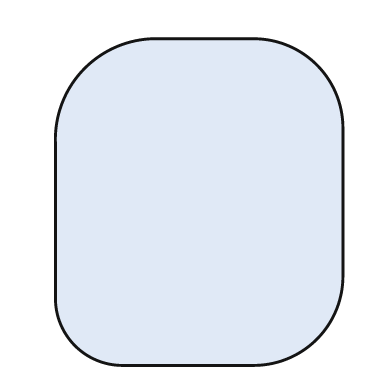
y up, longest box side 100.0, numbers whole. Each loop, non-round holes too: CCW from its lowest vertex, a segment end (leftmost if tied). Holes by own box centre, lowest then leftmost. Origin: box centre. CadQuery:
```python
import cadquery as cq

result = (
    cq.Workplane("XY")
    .moveTo(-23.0, -50.0)
    .lineTo(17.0, -50.0)
    .threePointArc((36.0, -42.0), (44.0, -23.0))
    .lineTo(44.0, 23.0)
    .threePointArc((36.0, 42.0), (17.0, 50.0))
    .lineTo(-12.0, 50.0)
    .threePointArc((-35.0, 41.0), (-44.0, 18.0))
    .lineTo(-44.0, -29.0)
    .threePointArc((-38.0, -44.0), (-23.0, -50.0))
    .close()
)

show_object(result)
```